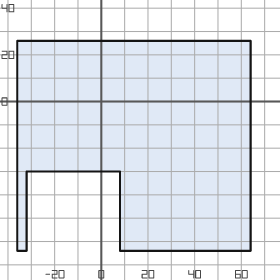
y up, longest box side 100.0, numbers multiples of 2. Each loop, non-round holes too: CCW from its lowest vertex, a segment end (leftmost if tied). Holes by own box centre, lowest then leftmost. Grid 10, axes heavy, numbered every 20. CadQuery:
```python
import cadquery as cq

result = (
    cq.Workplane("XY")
    .moveTo(-36.0, -64.0)
    .lineTo(-32.0, -64.0)
    .lineTo(-32.0, -30.0)
    .lineTo(8.0, -30.0)
    .lineTo(8.0, -64.0)
    .lineTo(64.0, -64.0)
    .lineTo(64.0, 26.0)
    .lineTo(-36.0, 26.0)
    .close()
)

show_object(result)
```